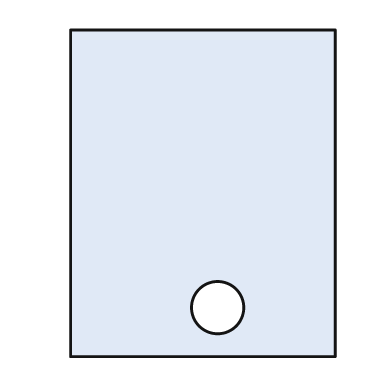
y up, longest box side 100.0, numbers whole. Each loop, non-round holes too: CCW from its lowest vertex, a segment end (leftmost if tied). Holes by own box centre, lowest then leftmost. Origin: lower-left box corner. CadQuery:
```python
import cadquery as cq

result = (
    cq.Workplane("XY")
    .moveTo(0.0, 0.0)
    .lineTo(81.0, 0.0)
    .lineTo(81.0, 100.0)
    .lineTo(0.0, 100.0)
    .close()
    .moveTo(45.0, 15.0)
    .circle(8.0)
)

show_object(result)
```